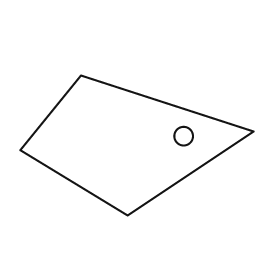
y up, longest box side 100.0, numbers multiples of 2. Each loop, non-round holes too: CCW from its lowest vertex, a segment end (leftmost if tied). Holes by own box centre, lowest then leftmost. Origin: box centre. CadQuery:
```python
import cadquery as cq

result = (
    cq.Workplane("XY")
    .moveTo(-4.0, -30.0)
    .lineTo(50.0, 6.0)
    .lineTo(-24.0, 30.0)
    .lineTo(-50.0, -2.0)
    .close()
    .moveTo(20.0, 4.0)
    .circle(4.0)
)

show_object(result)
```